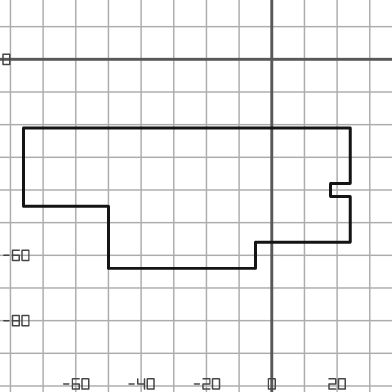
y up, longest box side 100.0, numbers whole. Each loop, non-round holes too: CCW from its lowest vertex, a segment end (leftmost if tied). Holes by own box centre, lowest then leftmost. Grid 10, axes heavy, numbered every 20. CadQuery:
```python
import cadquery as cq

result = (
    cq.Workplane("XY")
    .moveTo(-50.0, -64.0)
    .lineTo(-5.0, -64.0)
    .lineTo(-5.0, -56.0)
    .lineTo(24.0, -56.0)
    .lineTo(24.0, -42.0)
    .lineTo(18.0, -42.0)
    .lineTo(18.0, -38.0)
    .lineTo(24.0, -38.0)
    .lineTo(24.0, -21.0)
    .lineTo(-76.0, -21.0)
    .lineTo(-76.0, -45.0)
    .lineTo(-50.0, -45.0)
    .close()
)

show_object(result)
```